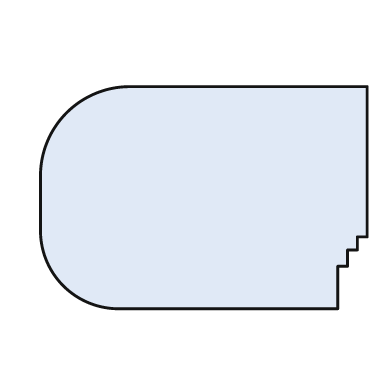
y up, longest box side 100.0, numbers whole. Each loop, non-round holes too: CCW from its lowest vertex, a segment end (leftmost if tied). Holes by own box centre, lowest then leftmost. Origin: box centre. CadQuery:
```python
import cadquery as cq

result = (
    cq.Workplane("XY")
    .moveTo(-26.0, -34.0)
    .lineTo(41.0, -34.0)
    .lineTo(41.0, -21.0)
    .lineTo(44.0, -21.0)
    .lineTo(44.0, -16.0)
    .lineTo(47.0, -16.0)
    .lineTo(47.0, -12.0)
    .lineTo(50.0, -12.0)
    .lineTo(50.0, 34.0)
    .lineTo(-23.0, 34.0)
    .threePointArc((-42.0, 26.0), (-50.0, 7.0))
    .lineTo(-50.0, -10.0)
    .threePointArc((-43.0, -27.0), (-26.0, -34.0))
    .close()
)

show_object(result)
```